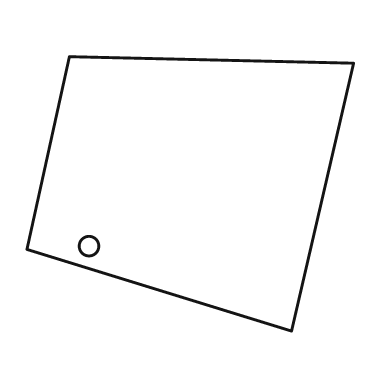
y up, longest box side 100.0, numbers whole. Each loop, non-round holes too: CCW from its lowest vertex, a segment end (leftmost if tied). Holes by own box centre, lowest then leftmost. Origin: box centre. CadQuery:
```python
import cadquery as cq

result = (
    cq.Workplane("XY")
    .moveTo(31.0, -42.0)
    .lineTo(50.0, 40.0)
    .lineTo(-37.0, 42.0)
    .lineTo(-50.0, -17.0)
    .close()
    .moveTo(-31.0, -16.0)
    .circle(3.0)
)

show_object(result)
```